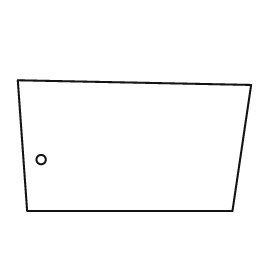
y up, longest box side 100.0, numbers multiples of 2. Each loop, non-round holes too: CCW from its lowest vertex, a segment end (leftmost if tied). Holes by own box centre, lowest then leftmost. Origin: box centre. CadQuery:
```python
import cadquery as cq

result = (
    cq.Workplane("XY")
    .moveTo(-46.0, -28.0)
    .lineTo(42.0, -28.0)
    .lineTo(50.0, 26.0)
    .lineTo(-50.0, 28.0)
    .close()
    .moveTo(-40.0, -6.0)
    .circle(2.0)
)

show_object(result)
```